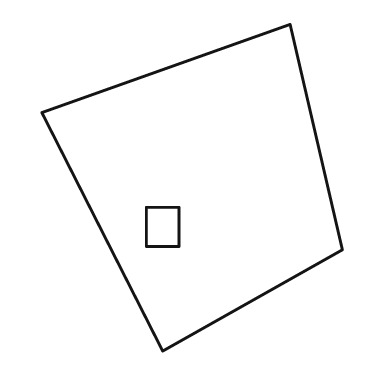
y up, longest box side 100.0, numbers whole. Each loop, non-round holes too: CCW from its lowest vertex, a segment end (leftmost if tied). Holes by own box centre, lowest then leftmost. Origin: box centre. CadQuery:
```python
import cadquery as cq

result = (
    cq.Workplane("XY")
    .moveTo(-9.0, -50.0)
    .lineTo(46.0, -19.0)
    .lineTo(30.0, 50.0)
    .lineTo(-46.0, 23.0)
    .close()
    .moveTo(-14.0, -18.0)
    .lineTo(-4.0, -18.0)
    .lineTo(-4.0, -6.0)
    .lineTo(-14.0, -6.0)
    .close()
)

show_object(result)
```